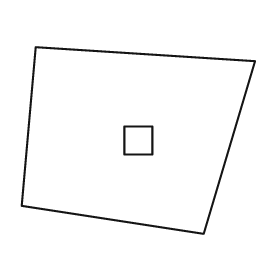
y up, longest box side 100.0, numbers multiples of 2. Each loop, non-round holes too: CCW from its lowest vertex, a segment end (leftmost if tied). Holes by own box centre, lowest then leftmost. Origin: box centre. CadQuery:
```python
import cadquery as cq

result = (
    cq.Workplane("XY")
    .moveTo(28.0, -40.0)
    .lineTo(50.0, 34.0)
    .lineTo(-44.0, 40.0)
    .lineTo(-50.0, -28.0)
    .close()
    .moveTo(-6.0, -6.0)
    .lineTo(6.0, -6.0)
    .lineTo(6.0, 6.0)
    .lineTo(-6.0, 6.0)
    .close()
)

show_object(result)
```